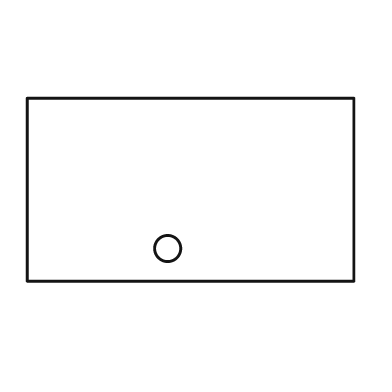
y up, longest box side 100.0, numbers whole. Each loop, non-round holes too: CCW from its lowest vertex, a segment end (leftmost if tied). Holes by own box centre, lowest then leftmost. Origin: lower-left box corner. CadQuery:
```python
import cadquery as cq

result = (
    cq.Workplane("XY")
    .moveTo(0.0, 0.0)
    .lineTo(100.0, 0.0)
    .lineTo(100.0, 56.0)
    .lineTo(0.0, 56.0)
    .close()
    .moveTo(43.0, 10.0)
    .circle(4.0)
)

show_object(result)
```